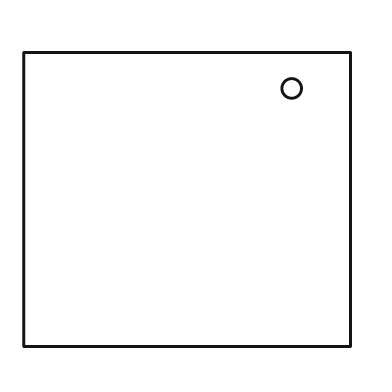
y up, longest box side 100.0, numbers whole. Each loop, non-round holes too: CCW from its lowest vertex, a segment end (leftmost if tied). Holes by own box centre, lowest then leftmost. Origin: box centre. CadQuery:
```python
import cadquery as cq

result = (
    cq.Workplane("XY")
    .moveTo(-50.0, -45.0)
    .lineTo(50.0, -45.0)
    .lineTo(50.0, 45.0)
    .lineTo(-50.0, 45.0)
    .close()
    .moveTo(32.0, 34.0)
    .circle(3.0)
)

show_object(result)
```